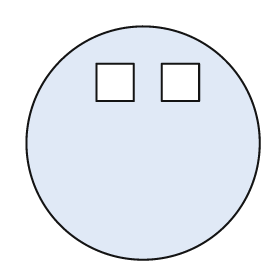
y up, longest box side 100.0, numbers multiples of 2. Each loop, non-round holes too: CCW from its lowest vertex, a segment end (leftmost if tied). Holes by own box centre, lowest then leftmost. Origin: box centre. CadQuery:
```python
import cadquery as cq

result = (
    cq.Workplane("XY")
    .moveTo(0.0, 0.0)
    .circle(50.0)
    .moveTo(-20.0, 18.0)
    .lineTo(-4.0, 18.0)
    .lineTo(-4.0, 34.0)
    .lineTo(-20.0, 34.0)
    .close()
    .moveTo(8.0, 18.0)
    .lineTo(24.0, 18.0)
    .lineTo(24.0, 34.0)
    .lineTo(8.0, 34.0)
    .close()
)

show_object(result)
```